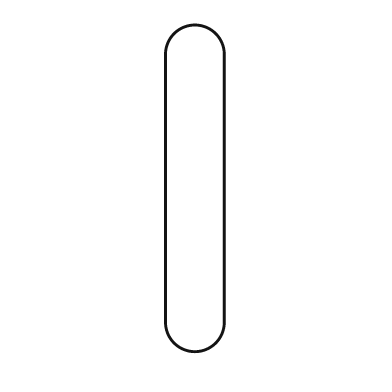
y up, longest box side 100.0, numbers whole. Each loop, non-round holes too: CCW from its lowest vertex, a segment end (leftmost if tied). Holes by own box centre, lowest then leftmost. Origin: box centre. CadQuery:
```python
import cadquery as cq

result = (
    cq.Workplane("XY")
    .moveTo(-9.0, -41.0)
    .threePointArc((0.0, -50.0), (9.0, -41.0))
    .lineTo(9.0, 41.0)
    .threePointArc((0.0, 50.0), (-9.0, 41.0))
    .close()
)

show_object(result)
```